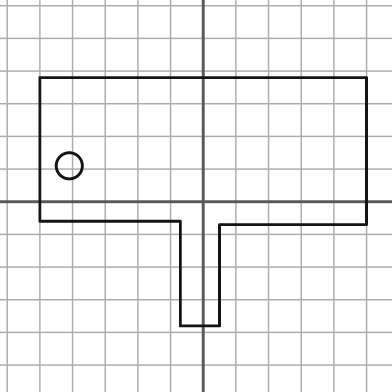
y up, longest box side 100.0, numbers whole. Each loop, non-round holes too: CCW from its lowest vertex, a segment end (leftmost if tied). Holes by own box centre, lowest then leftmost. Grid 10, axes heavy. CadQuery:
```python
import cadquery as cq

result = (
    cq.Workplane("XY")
    .moveTo(-7.0, -38.0)
    .lineTo(5.0, -38.0)
    .lineTo(5.0, -7.0)
    .lineTo(50.0, -7.0)
    .lineTo(50.0, 38.0)
    .lineTo(-50.0, 38.0)
    .lineTo(-50.0, -6.0)
    .lineTo(-7.0, -6.0)
    .close()
    .moveTo(-41.0, 11.0)
    .circle(4.0)
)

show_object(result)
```